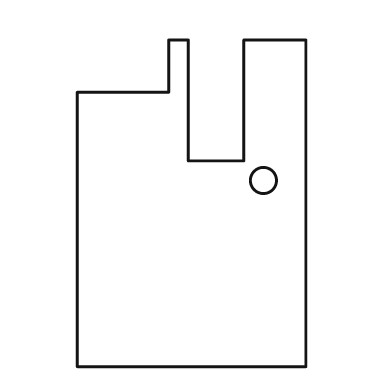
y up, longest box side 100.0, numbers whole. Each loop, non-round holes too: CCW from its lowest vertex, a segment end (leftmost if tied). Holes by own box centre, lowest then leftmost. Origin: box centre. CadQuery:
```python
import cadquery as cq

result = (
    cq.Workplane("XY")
    .moveTo(-35.0, -50.0)
    .lineTo(35.0, -50.0)
    .lineTo(35.0, 50.0)
    .lineTo(16.0, 50.0)
    .lineTo(16.0, 13.0)
    .lineTo(-1.0, 13.0)
    .lineTo(-1.0, 50.0)
    .lineTo(-7.0, 50.0)
    .lineTo(-7.0, 34.0)
    .lineTo(-35.0, 34.0)
    .close()
    .moveTo(22.0, 7.0)
    .circle(4.0)
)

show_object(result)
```